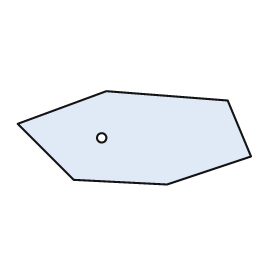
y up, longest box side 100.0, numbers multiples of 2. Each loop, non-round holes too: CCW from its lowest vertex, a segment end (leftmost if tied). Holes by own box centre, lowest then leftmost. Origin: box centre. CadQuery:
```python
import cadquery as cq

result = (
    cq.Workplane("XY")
    .moveTo(14.0, -20.0)
    .lineTo(50.0, -8.0)
    .lineTo(40.0, 16.0)
    .lineTo(-12.0, 20.0)
    .lineTo(-50.0, 6.0)
    .lineTo(-26.0, -18.0)
    .close()
    .moveTo(-14.0, 0.0)
    .circle(2.0)
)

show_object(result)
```